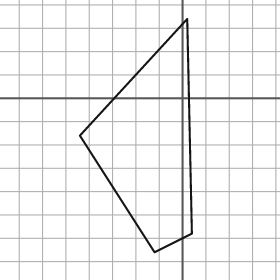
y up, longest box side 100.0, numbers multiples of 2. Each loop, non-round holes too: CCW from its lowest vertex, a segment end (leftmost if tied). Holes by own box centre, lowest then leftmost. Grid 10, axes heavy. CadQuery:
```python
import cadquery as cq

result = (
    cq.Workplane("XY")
    .moveTo(-12.0, -66.0)
    .lineTo(4.0, -58.0)
    .lineTo(2.0, 34.0)
    .lineTo(-44.0, -16.0)
    .close()
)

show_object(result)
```